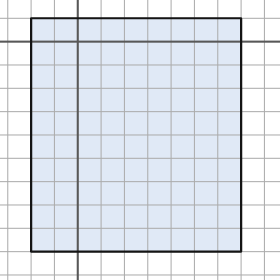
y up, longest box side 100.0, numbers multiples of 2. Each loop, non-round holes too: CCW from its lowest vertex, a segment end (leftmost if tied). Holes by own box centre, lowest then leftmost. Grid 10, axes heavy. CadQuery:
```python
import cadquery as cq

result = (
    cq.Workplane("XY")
    .moveTo(-20.0, -90.0)
    .lineTo(70.0, -90.0)
    .lineTo(70.0, 10.0)
    .lineTo(-20.0, 10.0)
    .close()
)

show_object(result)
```